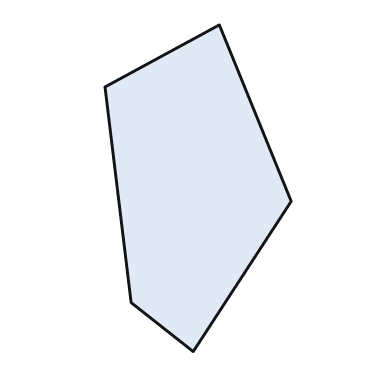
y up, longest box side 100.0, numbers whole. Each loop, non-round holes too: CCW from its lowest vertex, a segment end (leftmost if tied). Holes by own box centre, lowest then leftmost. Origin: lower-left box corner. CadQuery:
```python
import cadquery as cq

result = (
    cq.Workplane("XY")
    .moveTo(27.0, 0.0)
    .lineTo(57.0, 46.0)
    .lineTo(35.0, 100.0)
    .lineTo(0.0, 81.0)
    .lineTo(8.0, 15.0)
    .close()
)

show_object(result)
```